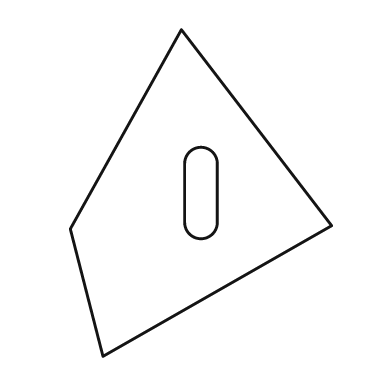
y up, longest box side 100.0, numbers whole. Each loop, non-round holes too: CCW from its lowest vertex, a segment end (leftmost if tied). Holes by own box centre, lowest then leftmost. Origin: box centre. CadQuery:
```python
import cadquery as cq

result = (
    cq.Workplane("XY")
    .moveTo(-30.0, -50.0)
    .lineTo(40.0, -10.0)
    .lineTo(-6.0, 50.0)
    .lineTo(-40.0, -11.0)
    .close()
    .moveTo(-5.0, -9.0)
    .threePointArc((0.0, -14.0), (5.0, -9.0))
    .lineTo(5.0, 9.0)
    .threePointArc((0.0, 14.0), (-5.0, 9.0))
    .close()
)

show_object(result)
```